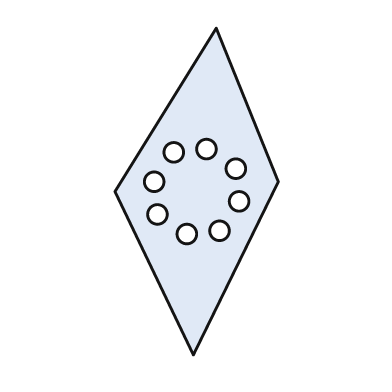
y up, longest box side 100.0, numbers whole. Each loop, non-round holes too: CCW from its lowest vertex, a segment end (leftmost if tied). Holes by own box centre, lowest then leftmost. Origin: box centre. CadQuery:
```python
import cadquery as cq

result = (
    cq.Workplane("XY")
    .moveTo(-1.0, -50.0)
    .lineTo(25.0, 3.0)
    .lineTo(6.0, 50.0)
    .lineTo(-25.0, 0.0)
    .close()
    .moveTo(-3.0, -13.0)
    .circle(3.0)
    .moveTo(7.0, -12.0)
    .circle(3.0)
    .moveTo(-12.0, -7.0)
    .circle(3.0)
    .moveTo(13.0, -3.0)
    .circle(3.0)
    .moveTo(-13.0, 3.0)
    .circle(3.0)
    .moveTo(12.0, 7.0)
    .circle(3.0)
    .moveTo(-7.0, 12.0)
    .circle(3.0)
    .moveTo(3.0, 13.0)
    .circle(3.0)
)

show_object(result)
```